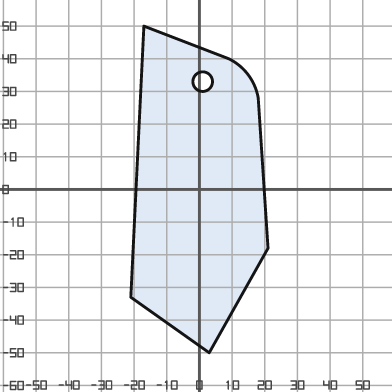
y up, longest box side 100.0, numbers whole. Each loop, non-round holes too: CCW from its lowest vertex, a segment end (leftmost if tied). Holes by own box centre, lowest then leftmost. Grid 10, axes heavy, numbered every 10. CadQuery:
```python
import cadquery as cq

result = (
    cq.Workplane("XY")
    .moveTo(3.0, -50.0)
    .lineTo(21.0, -18.0)
    .lineTo(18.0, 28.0)
    .threePointArc((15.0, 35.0), (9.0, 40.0))
    .lineTo(-17.0, 50.0)
    .lineTo(-21.0, -33.0)
    .close()
    .moveTo(1.0, 33.0)
    .circle(3.0)
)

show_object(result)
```